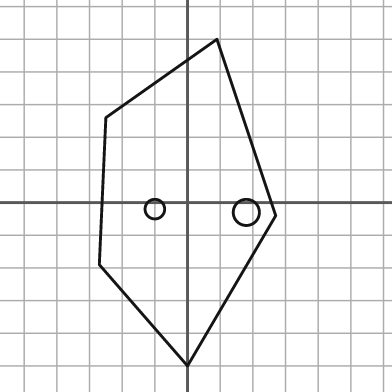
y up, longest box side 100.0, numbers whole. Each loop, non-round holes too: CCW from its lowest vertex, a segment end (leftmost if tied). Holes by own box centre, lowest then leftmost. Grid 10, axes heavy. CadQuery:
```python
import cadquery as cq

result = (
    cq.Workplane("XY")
    .moveTo(0.0, -50.0)
    .lineTo(27.0, -4.0)
    .lineTo(9.0, 50.0)
    .lineTo(-25.0, 26.0)
    .lineTo(-27.0, -19.0)
    .close()
    .moveTo(18.0, -3.0)
    .circle(4.0)
    .moveTo(-10.0, -2.0)
    .circle(3.0)
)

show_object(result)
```